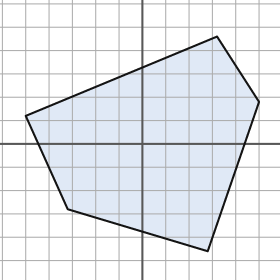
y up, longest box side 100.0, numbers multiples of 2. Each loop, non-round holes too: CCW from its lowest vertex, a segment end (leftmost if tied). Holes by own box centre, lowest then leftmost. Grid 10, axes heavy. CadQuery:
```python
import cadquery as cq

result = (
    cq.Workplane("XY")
    .moveTo(28.0, -46.0)
    .lineTo(50.0, 18.0)
    .lineTo(32.0, 46.0)
    .lineTo(-50.0, 12.0)
    .lineTo(-32.0, -28.0)
    .close()
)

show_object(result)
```